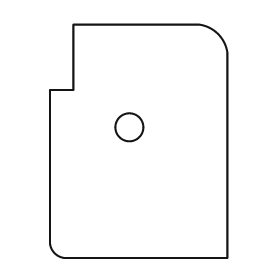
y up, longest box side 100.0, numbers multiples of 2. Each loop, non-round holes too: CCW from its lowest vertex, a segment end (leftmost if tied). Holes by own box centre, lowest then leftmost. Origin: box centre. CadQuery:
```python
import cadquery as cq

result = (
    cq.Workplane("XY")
    .moveTo(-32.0, -50.0)
    .lineTo(38.0, -50.0)
    .lineTo(38.0, 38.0)
    .threePointArc((34.0, 46.0), (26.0, 50.0))
    .lineTo(-28.0, 50.0)
    .lineTo(-28.0, 22.0)
    .lineTo(-38.0, 22.0)
    .lineTo(-38.0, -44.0)
    .threePointArc((-36.0, -48.0), (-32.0, -50.0))
    .close()
    .moveTo(-4.0, 6.0)
    .circle(6.0)
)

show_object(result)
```